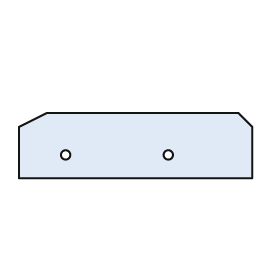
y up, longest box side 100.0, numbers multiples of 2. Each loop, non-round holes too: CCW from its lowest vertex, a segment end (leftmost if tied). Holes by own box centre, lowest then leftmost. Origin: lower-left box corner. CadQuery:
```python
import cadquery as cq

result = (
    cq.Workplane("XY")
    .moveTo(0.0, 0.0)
    .lineTo(100.0, 0.0)
    .lineTo(100.0, 22.0)
    .lineTo(94.0, 28.0)
    .lineTo(12.0, 28.0)
    .lineTo(0.0, 22.0)
    .close()
    .moveTo(20.0, 10.0)
    .circle(2.0)
    .moveTo(64.0, 10.0)
    .circle(2.0)
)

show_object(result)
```